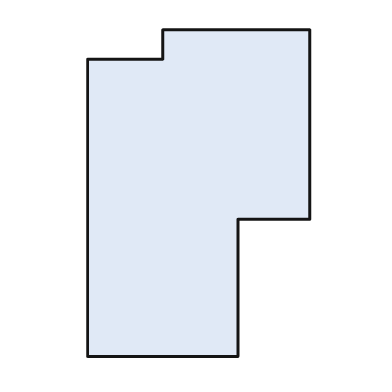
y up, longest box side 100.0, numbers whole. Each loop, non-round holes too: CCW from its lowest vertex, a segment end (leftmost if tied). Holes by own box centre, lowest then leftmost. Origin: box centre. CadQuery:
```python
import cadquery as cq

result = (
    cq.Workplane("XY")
    .moveTo(-34.0, -50.0)
    .lineTo(12.0, -50.0)
    .lineTo(12.0, -8.0)
    .lineTo(34.0, -8.0)
    .lineTo(34.0, 50.0)
    .lineTo(-11.0, 50.0)
    .lineTo(-11.0, 41.0)
    .lineTo(-34.0, 41.0)
    .close()
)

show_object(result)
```